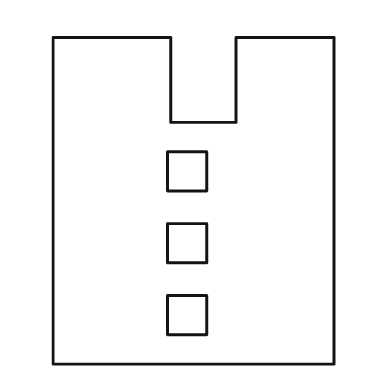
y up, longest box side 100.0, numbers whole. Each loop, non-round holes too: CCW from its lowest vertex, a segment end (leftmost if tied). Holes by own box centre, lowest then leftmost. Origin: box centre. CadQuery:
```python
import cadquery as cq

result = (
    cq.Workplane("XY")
    .moveTo(-43.0, -50.0)
    .lineTo(43.0, -50.0)
    .lineTo(43.0, 50.0)
    .lineTo(13.0, 50.0)
    .lineTo(13.0, 24.0)
    .lineTo(-7.0, 24.0)
    .lineTo(-7.0, 50.0)
    .lineTo(-43.0, 50.0)
    .close()
    .moveTo(-8.0, -41.0)
    .lineTo(4.0, -41.0)
    .lineTo(4.0, -29.0)
    .lineTo(-8.0, -29.0)
    .close()
    .moveTo(-8.0, -19.0)
    .lineTo(4.0, -19.0)
    .lineTo(4.0, -7.0)
    .lineTo(-8.0, -7.0)
    .close()
    .moveTo(-8.0, 3.0)
    .lineTo(4.0, 3.0)
    .lineTo(4.0, 15.0)
    .lineTo(-8.0, 15.0)
    .close()
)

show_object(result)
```